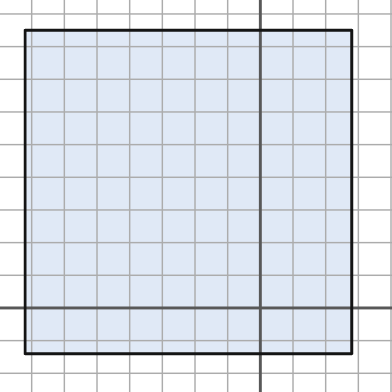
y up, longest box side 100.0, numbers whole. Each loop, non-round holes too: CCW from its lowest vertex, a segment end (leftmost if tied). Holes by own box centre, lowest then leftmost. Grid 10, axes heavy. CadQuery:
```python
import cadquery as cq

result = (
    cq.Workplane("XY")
    .moveTo(-72.0, -14.0)
    .lineTo(28.0, -14.0)
    .lineTo(28.0, 85.0)
    .lineTo(-72.0, 85.0)
    .close()
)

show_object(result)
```